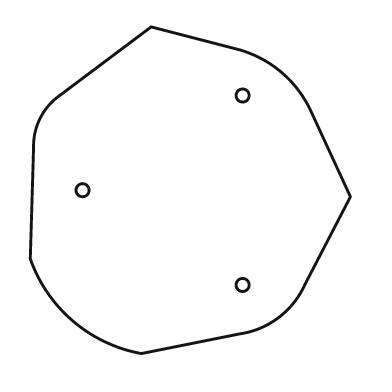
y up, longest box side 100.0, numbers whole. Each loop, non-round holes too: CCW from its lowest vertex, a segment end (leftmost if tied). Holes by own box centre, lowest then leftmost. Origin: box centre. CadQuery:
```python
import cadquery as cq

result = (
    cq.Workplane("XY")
    .moveTo(-15.0, -50.0)
    .lineTo(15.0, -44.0)
    .threePointArc((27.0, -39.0), (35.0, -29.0))
    .lineTo(49.0, -2.0)
    .lineTo(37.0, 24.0)
    .threePointArc((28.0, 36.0), (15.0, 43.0))
    .lineTo(-12.0, 50.0)
    .lineTo(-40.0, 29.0)
    .threePointArc((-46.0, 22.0), (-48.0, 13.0))
    .lineTo(-49.0, -21.0)
    .threePointArc((-36.0, -40.0), (-15.0, -50.0))
    .close()
    .moveTo(16.0, -29.0)
    .circle(2.0)
    .moveTo(-33.0, 0.0)
    .circle(2.0)
    .moveTo(16.0, 29.0)
    .circle(2.0)
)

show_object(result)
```